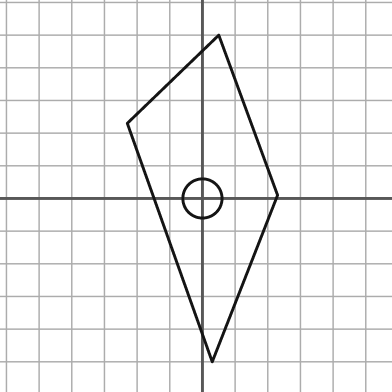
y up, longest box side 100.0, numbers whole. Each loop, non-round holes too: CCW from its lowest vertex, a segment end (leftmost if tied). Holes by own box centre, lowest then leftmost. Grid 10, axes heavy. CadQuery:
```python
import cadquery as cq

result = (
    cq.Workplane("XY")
    .moveTo(3.0, -50.0)
    .lineTo(23.0, 1.0)
    .lineTo(5.0, 50.0)
    .lineTo(-23.0, 23.0)
    .close()
    .moveTo(0.0, 0.0)
    .circle(6.0)
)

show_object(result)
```